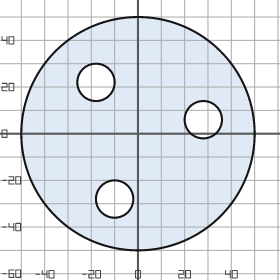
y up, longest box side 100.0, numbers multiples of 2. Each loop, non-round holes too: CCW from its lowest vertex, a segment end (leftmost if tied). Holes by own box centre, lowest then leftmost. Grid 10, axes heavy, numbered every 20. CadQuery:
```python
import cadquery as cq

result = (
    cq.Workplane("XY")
    .moveTo(0.0, 0.0)
    .circle(50.0)
    .moveTo(-10.0, -28.0)
    .circle(8.0)
    .moveTo(28.0, 6.0)
    .circle(8.0)
    .moveTo(-18.0, 22.0)
    .circle(8.0)
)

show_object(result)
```